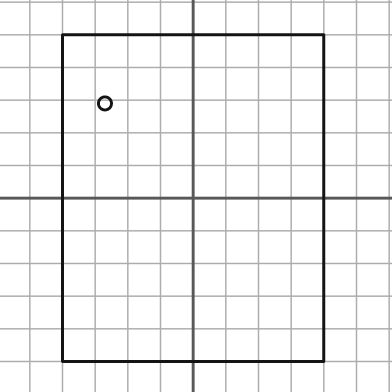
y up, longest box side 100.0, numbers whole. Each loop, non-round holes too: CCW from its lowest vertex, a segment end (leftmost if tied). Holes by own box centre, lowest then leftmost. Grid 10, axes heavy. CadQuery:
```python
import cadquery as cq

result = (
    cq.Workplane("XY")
    .moveTo(-40.0, -50.0)
    .lineTo(40.0, -50.0)
    .lineTo(40.0, 50.0)
    .lineTo(-40.0, 50.0)
    .close()
    .moveTo(-27.0, 29.0)
    .circle(2.0)
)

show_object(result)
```